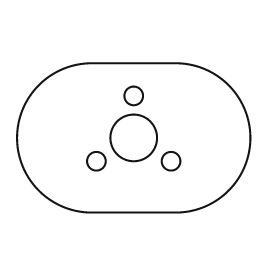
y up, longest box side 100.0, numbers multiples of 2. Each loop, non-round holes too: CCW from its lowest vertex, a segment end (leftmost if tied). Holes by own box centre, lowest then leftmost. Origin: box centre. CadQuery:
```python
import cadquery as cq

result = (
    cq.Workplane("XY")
    .moveTo(-18.0, -32.0)
    .lineTo(18.0, -32.0)
    .threePointArc((50.0, 0.0), (18.0, 32.0))
    .lineTo(-18.0, 32.0)
    .threePointArc((-50.0, 0.0), (-18.0, -32.0))
    .close()
    .moveTo(-16.0, -10.0)
    .circle(4.0)
    .moveTo(16.0, -10.0)
    .circle(4.0)
    .moveTo(0.0, 0.0)
    .circle(10.0)
    .moveTo(0.0, 18.0)
    .circle(4.0)
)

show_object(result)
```